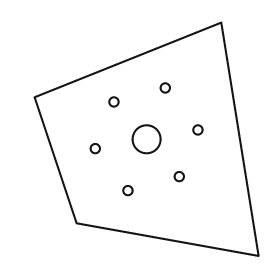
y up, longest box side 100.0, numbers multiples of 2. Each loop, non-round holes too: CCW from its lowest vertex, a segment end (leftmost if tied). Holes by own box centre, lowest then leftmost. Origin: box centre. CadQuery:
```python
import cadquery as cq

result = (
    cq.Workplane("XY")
    .moveTo(48.0, -50.0)
    .lineTo(32.0, 50.0)
    .lineTo(-48.0, 18.0)
    .lineTo(-30.0, -36.0)
    .close()
    .moveTo(-8.0, -22.0)
    .circle(2.0)
    .moveTo(14.0, -16.0)
    .circle(2.0)
    .moveTo(-22.0, -4.0)
    .circle(2.0)
    .moveTo(0.0, 0.0)
    .circle(6.0)
    .moveTo(22.0, 4.0)
    .circle(2.0)
    .moveTo(-14.0, 16.0)
    .circle(2.0)
    .moveTo(8.0, 22.0)
    .circle(2.0)
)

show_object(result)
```